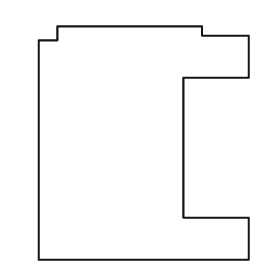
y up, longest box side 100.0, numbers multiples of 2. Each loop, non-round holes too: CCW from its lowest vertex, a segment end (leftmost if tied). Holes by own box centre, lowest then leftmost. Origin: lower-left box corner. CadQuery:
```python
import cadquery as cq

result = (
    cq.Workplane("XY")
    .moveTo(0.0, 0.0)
    .lineTo(90.0, 0.0)
    .lineTo(90.0, 18.0)
    .lineTo(62.0, 18.0)
    .lineTo(62.0, 78.0)
    .lineTo(90.0, 78.0)
    .lineTo(90.0, 96.0)
    .lineTo(70.0, 96.0)
    .lineTo(70.0, 100.0)
    .lineTo(8.0, 100.0)
    .lineTo(8.0, 94.0)
    .lineTo(0.0, 94.0)
    .close()
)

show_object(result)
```